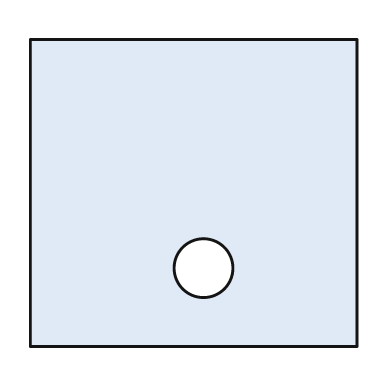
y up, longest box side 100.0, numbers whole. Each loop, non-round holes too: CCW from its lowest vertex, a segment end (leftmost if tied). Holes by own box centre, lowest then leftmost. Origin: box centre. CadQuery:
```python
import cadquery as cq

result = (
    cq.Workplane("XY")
    .moveTo(-50.0, -47.0)
    .lineTo(50.0, -47.0)
    .lineTo(50.0, 47.0)
    .lineTo(-50.0, 47.0)
    .close()
    .moveTo(3.0, -23.0)
    .circle(9.0)
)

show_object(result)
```